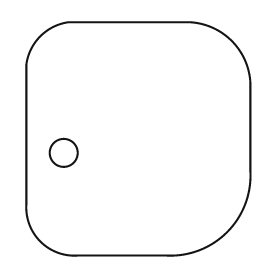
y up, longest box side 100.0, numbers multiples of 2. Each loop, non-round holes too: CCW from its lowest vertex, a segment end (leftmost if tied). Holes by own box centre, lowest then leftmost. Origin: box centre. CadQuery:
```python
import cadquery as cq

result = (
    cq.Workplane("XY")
    .moveTo(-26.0, -50.0)
    .lineTo(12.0, -50.0)
    .threePointArc((38.0, -40.0), (48.0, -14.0))
    .lineTo(48.0, 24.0)
    .threePointArc((40.0, 42.0), (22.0, 50.0))
    .lineTo(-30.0, 50.0)
    .threePointArc((-42.0, 44.0), (-48.0, 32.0))
    .lineTo(-48.0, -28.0)
    .threePointArc((-42.0, -44.0), (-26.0, -50.0))
    .close()
    .moveTo(-32.0, -6.0)
    .circle(6.0)
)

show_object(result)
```